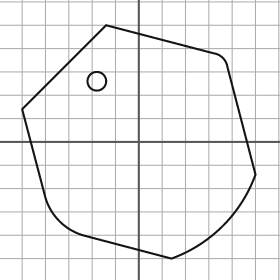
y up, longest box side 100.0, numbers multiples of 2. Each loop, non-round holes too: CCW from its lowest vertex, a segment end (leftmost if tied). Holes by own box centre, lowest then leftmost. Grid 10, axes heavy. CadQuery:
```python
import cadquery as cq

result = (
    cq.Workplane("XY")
    .moveTo(14.0, -50.0)
    .threePointArc((36.0, -36.0), (50.0, -14.0))
    .lineTo(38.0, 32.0)
    .threePointArc((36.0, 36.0), (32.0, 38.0))
    .lineTo(-14.0, 50.0)
    .lineTo(-50.0, 14.0)
    .lineTo(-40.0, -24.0)
    .threePointArc((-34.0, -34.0), (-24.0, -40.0))
    .close()
    .moveTo(-18.0, 26.0)
    .circle(4.0)
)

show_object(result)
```